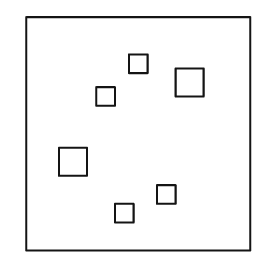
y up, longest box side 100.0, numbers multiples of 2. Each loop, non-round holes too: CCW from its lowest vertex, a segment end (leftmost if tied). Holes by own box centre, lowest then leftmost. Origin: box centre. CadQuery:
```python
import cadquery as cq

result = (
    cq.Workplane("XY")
    .moveTo(-48.0, -50.0)
    .lineTo(48.0, -50.0)
    .lineTo(48.0, 50.0)
    .lineTo(-48.0, 50.0)
    .close()
    .moveTo(-10.0, -38.0)
    .lineTo(-2.0, -38.0)
    .lineTo(-2.0, -30.0)
    .lineTo(-10.0, -30.0)
    .close()
    .moveTo(8.0, -30.0)
    .lineTo(16.0, -30.0)
    .lineTo(16.0, -22.0)
    .lineTo(8.0, -22.0)
    .close()
    .moveTo(-34.0, -18.0)
    .lineTo(-22.0, -18.0)
    .lineTo(-22.0, -6.0)
    .lineTo(-34.0, -6.0)
    .close()
    .moveTo(-18.0, 12.0)
    .lineTo(-10.0, 12.0)
    .lineTo(-10.0, 20.0)
    .lineTo(-18.0, 20.0)
    .close()
    .moveTo(16.0, 16.0)
    .lineTo(28.0, 16.0)
    .lineTo(28.0, 28.0)
    .lineTo(16.0, 28.0)
    .close()
    .moveTo(-4.0, 26.0)
    .lineTo(4.0, 26.0)
    .lineTo(4.0, 34.0)
    .lineTo(-4.0, 34.0)
    .close()
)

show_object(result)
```